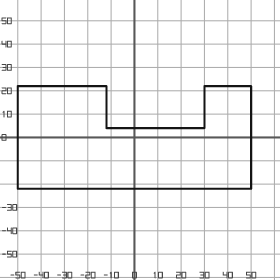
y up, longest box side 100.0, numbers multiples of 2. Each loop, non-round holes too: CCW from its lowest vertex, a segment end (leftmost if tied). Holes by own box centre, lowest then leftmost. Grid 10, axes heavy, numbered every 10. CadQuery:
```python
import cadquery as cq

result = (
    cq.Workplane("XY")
    .moveTo(-50.0, -22.0)
    .lineTo(50.0, -22.0)
    .lineTo(50.0, 22.0)
    .lineTo(30.0, 22.0)
    .lineTo(30.0, 4.0)
    .lineTo(-12.0, 4.0)
    .lineTo(-12.0, 22.0)
    .lineTo(-50.0, 22.0)
    .close()
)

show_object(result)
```